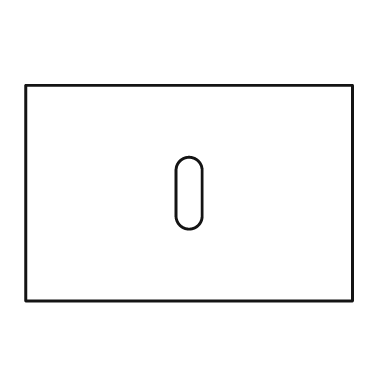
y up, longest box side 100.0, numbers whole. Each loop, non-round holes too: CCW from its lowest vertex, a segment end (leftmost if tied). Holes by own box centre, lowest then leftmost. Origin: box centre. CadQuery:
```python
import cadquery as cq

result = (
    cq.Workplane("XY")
    .moveTo(-50.0, -33.0)
    .lineTo(50.0, -33.0)
    .lineTo(50.0, 33.0)
    .lineTo(-50.0, 33.0)
    .close()
    .moveTo(-4.0, -7.0)
    .threePointArc((0.0, -11.0), (4.0, -7.0))
    .lineTo(4.0, 7.0)
    .threePointArc((0.0, 11.0), (-4.0, 7.0))
    .close()
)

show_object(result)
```